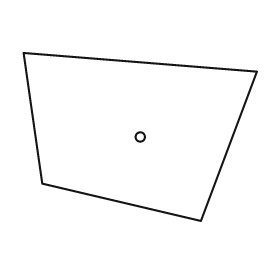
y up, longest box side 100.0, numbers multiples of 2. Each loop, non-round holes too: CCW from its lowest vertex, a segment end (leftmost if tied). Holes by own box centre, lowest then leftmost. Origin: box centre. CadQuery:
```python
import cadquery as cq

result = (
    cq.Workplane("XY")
    .moveTo(26.0, -36.0)
    .lineTo(50.0, 28.0)
    .lineTo(-50.0, 36.0)
    .lineTo(-42.0, -20.0)
    .close()
    .moveTo(0.0, 0.0)
    .circle(2.0)
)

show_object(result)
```